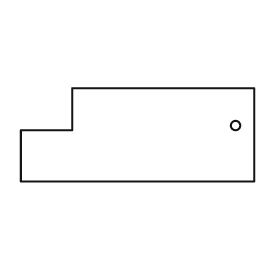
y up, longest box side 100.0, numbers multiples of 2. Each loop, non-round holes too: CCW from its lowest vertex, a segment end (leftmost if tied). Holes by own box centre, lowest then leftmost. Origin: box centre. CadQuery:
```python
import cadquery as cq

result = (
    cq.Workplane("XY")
    .moveTo(-50.0, -20.0)
    .lineTo(50.0, -20.0)
    .lineTo(50.0, 20.0)
    .lineTo(-28.0, 20.0)
    .lineTo(-28.0, 2.0)
    .lineTo(-50.0, 2.0)
    .close()
    .moveTo(42.0, 4.0)
    .circle(2.0)
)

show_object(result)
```